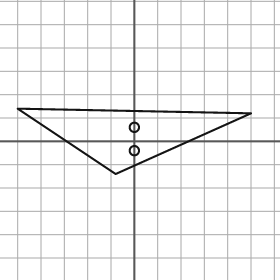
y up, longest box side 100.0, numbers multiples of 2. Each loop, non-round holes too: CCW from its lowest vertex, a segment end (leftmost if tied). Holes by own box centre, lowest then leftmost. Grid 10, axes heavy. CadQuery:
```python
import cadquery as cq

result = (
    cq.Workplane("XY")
    .moveTo(-8.0, -14.0)
    .lineTo(50.0, 12.0)
    .lineTo(-50.0, 14.0)
    .close()
    .moveTo(0.0, -4.0)
    .circle(2.0)
    .moveTo(0.0, 6.0)
    .circle(2.0)
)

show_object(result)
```